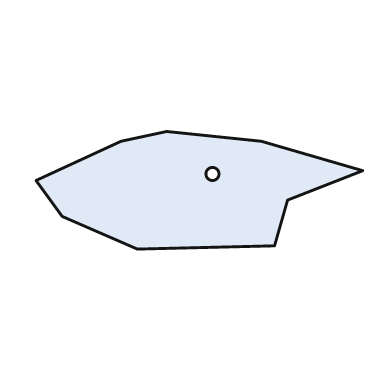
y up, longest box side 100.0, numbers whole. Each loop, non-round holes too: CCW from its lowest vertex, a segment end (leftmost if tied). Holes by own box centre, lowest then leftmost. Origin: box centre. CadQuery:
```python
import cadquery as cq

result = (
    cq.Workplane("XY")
    .moveTo(-19.0, -18.0)
    .lineTo(23.0, -17.0)
    .lineTo(27.0, -3.0)
    .lineTo(50.0, 6.0)
    .lineTo(19.0, 15.0)
    .lineTo(-10.0, 18.0)
    .lineTo(-24.0, 15.0)
    .lineTo(-50.0, 3.0)
    .lineTo(-42.0, -8.0)
    .close()
    .moveTo(4.0, 5.0)
    .circle(2.0)
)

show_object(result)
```